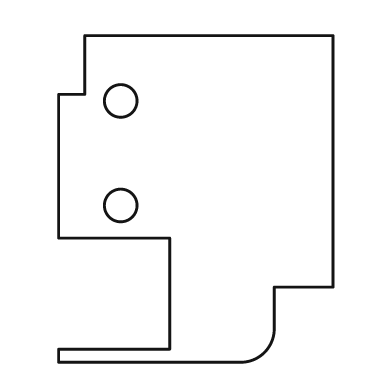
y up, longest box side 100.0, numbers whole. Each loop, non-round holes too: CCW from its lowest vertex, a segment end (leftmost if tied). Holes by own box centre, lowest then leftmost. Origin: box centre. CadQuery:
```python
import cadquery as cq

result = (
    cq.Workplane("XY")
    .moveTo(-42.0, -50.0)
    .lineTo(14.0, -50.0)
    .threePointArc((21.0, -47.0), (24.0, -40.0))
    .lineTo(24.0, -27.0)
    .lineTo(42.0, -27.0)
    .lineTo(42.0, 50.0)
    .lineTo(-34.0, 50.0)
    .lineTo(-34.0, 32.0)
    .lineTo(-42.0, 32.0)
    .lineTo(-42.0, -12.0)
    .lineTo(-8.0, -12.0)
    .lineTo(-8.0, -46.0)
    .lineTo(-42.0, -46.0)
    .close()
    .moveTo(-23.0, -2.0)
    .circle(5.0)
    .moveTo(-23.0, 30.0)
    .circle(5.0)
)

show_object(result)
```